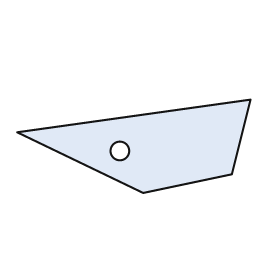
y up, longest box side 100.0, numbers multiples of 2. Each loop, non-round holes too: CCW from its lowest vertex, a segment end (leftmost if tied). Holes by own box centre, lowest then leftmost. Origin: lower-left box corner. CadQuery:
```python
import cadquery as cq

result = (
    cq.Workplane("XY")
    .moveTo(54.0, 0.0)
    .lineTo(92.0, 8.0)
    .lineTo(100.0, 40.0)
    .lineTo(0.0, 26.0)
    .close()
    .moveTo(44.0, 18.0)
    .circle(4.0)
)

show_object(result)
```